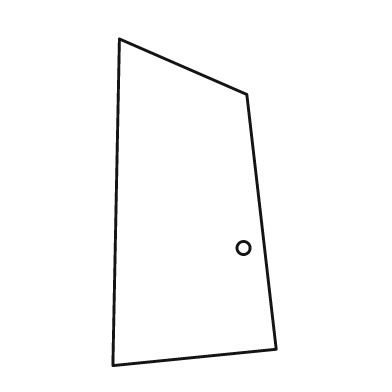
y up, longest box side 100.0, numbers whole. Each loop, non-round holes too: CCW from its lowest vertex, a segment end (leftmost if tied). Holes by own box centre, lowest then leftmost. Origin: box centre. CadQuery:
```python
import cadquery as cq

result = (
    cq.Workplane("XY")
    .moveTo(-25.0, -50.0)
    .lineTo(25.0, -45.0)
    .lineTo(16.0, 33.0)
    .lineTo(-23.0, 50.0)
    .close()
    .moveTo(15.0, -14.0)
    .circle(2.0)
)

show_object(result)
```